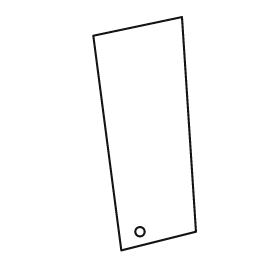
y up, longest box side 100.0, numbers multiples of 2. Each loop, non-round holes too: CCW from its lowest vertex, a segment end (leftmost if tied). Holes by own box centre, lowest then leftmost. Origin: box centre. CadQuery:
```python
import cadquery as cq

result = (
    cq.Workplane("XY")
    .moveTo(-10.0, -50.0)
    .lineTo(22.0, -42.0)
    .lineTo(16.0, 50.0)
    .lineTo(-22.0, 42.0)
    .close()
    .moveTo(-2.0, -42.0)
    .circle(2.0)
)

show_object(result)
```